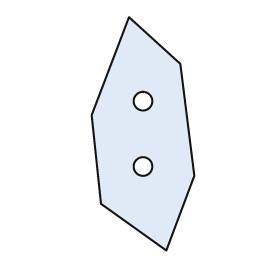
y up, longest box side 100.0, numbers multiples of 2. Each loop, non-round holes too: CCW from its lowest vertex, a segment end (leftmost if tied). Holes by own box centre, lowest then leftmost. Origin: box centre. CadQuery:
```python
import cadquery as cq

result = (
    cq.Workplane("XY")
    .moveTo(10.0, -50.0)
    .lineTo(22.0, -18.0)
    .lineTo(16.0, 30.0)
    .lineTo(-6.0, 50.0)
    .lineTo(-22.0, 8.0)
    .lineTo(-18.0, -30.0)
    .close()
    .moveTo(0.0, -14.0)
    .circle(4.0)
    .moveTo(0.0, 14.0)
    .circle(4.0)
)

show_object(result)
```